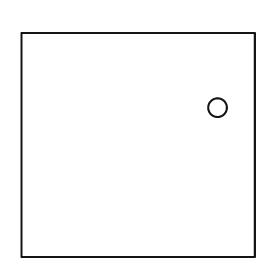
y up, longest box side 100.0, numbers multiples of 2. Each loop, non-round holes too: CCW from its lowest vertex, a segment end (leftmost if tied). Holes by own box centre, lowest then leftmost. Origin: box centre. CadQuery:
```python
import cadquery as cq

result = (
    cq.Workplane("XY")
    .moveTo(-50.0, -48.0)
    .lineTo(50.0, -48.0)
    .lineTo(50.0, 48.0)
    .lineTo(-50.0, 48.0)
    .close()
    .moveTo(34.0, 16.0)
    .circle(4.0)
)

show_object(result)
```